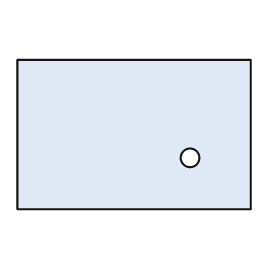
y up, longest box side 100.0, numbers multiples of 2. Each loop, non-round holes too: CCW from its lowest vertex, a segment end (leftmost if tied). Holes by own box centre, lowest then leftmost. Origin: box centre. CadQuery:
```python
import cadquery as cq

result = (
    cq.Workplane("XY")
    .moveTo(-50.0, -32.0)
    .lineTo(50.0, -32.0)
    .lineTo(50.0, 32.0)
    .lineTo(-50.0, 32.0)
    .close()
    .moveTo(24.0, -10.0)
    .circle(4.0)
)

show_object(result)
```